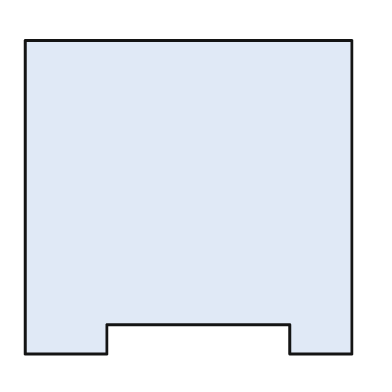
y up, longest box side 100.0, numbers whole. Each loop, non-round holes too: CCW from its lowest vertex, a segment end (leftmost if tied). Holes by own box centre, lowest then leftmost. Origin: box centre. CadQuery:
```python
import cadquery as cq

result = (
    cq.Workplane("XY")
    .moveTo(-50.0, -48.0)
    .lineTo(-25.0, -48.0)
    .lineTo(-25.0, -39.0)
    .lineTo(31.0, -39.0)
    .lineTo(31.0, -48.0)
    .lineTo(50.0, -48.0)
    .lineTo(50.0, 48.0)
    .lineTo(-50.0, 48.0)
    .close()
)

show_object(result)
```